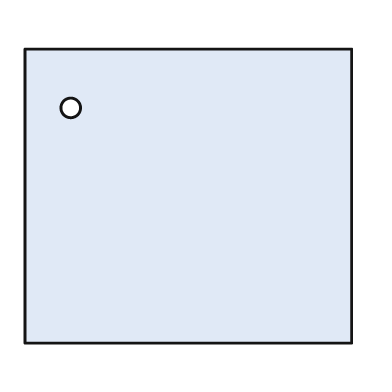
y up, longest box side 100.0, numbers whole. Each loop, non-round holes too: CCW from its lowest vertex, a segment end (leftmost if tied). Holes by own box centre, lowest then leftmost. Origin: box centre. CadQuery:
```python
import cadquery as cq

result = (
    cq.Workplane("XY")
    .moveTo(-50.0, -45.0)
    .lineTo(50.0, -45.0)
    .lineTo(50.0, 45.0)
    .lineTo(-50.0, 45.0)
    .close()
    .moveTo(-36.0, 27.0)
    .circle(3.0)
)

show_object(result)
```